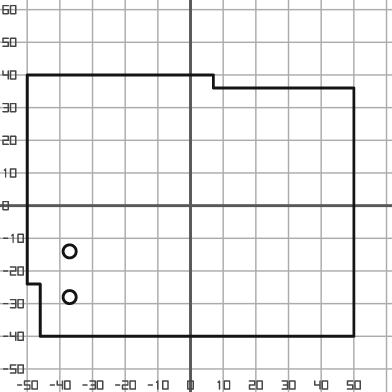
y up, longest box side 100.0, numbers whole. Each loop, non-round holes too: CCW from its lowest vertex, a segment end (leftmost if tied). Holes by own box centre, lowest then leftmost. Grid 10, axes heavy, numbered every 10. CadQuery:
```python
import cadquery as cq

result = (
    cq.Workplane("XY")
    .moveTo(-46.0, -40.0)
    .lineTo(50.0, -40.0)
    .lineTo(50.0, 36.0)
    .lineTo(7.0, 36.0)
    .lineTo(7.0, 40.0)
    .lineTo(-50.0, 40.0)
    .lineTo(-50.0, -24.0)
    .lineTo(-46.0, -24.0)
    .close()
    .moveTo(-37.0, -28.0)
    .circle(2.0)
    .moveTo(-37.0, -14.0)
    .circle(2.0)
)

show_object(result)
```